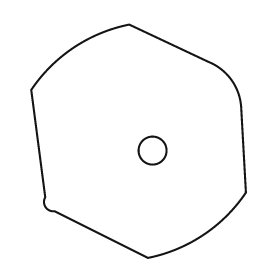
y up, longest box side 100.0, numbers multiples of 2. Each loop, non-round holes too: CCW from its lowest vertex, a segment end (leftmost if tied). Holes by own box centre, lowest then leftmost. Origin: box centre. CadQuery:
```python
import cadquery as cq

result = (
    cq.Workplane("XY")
    .moveTo(4.0, -50.0)
    .threePointArc((28.0, -40.0), (46.0, -22.0))
    .lineTo(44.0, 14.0)
    .threePointArc((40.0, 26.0), (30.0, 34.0))
    .lineTo(-4.0, 50.0)
    .threePointArc((-28.0, 40.0), (-46.0, 22.0))
    .lineTo(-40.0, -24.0)
    .threePointArc((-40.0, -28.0), (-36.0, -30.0))
    .close()
    .moveTo(6.0, -4.0)
    .circle(6.0)
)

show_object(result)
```